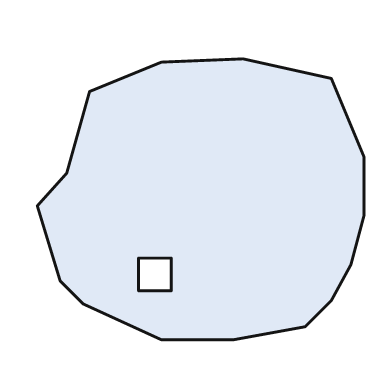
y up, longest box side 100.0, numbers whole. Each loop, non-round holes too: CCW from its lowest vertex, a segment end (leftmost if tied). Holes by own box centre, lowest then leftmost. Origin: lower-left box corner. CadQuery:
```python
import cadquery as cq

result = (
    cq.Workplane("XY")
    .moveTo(38.0, 0.0)
    .lineTo(60.0, 0.0)
    .lineTo(82.0, 4.0)
    .lineTo(90.0, 12.0)
    .lineTo(96.0, 23.0)
    .lineTo(100.0, 38.0)
    .lineTo(100.0, 56.0)
    .lineTo(90.0, 80.0)
    .lineTo(63.0, 86.0)
    .lineTo(38.0, 85.0)
    .lineTo(16.0, 76.0)
    .lineTo(9.0, 51.0)
    .lineTo(0.0, 41.0)
    .lineTo(7.0, 18.0)
    .lineTo(14.0, 11.0)
    .close()
    .moveTo(31.0, 15.0)
    .lineTo(41.0, 15.0)
    .lineTo(41.0, 25.0)
    .lineTo(31.0, 25.0)
    .close()
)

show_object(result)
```